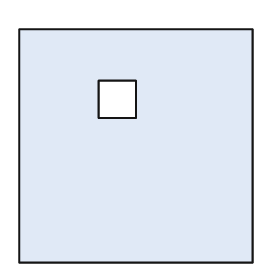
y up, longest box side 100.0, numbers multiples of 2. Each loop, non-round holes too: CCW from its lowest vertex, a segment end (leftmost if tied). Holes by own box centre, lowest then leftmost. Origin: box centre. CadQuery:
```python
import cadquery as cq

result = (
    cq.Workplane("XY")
    .moveTo(-50.0, -50.0)
    .lineTo(50.0, -50.0)
    .lineTo(50.0, 50.0)
    .lineTo(-50.0, 50.0)
    .close()
    .moveTo(-16.0, 12.0)
    .lineTo(0.0, 12.0)
    .lineTo(0.0, 28.0)
    .lineTo(-16.0, 28.0)
    .close()
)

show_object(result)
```